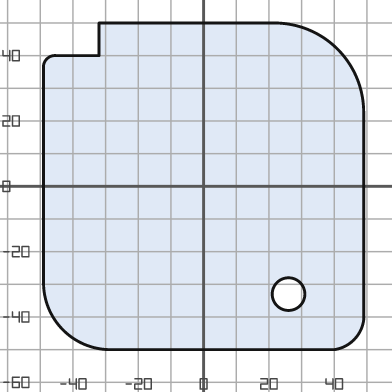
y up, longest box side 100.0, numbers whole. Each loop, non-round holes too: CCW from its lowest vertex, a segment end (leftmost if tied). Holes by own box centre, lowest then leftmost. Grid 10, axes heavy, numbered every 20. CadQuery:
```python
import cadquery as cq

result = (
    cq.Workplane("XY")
    .moveTo(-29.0, -50.0)
    .lineTo(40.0, -50.0)
    .threePointArc((46.0, -47.0), (49.0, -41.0))
    .lineTo(49.0, 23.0)
    .threePointArc((41.0, 42.0), (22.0, 50.0))
    .lineTo(-32.0, 50.0)
    .lineTo(-32.0, 40.0)
    .lineTo(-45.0, 40.0)
    .threePointArc((-48.0, 39.0), (-49.0, 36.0))
    .lineTo(-49.0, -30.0)
    .threePointArc((-43.0, -44.0), (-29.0, -50.0))
    .close()
    .moveTo(26.0, -33.0)
    .circle(5.0)
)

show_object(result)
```